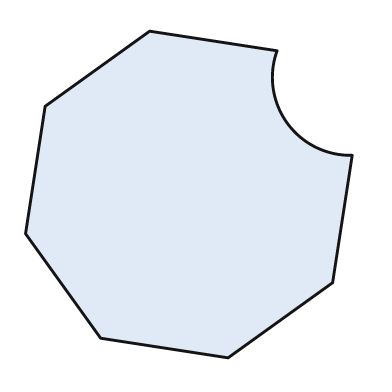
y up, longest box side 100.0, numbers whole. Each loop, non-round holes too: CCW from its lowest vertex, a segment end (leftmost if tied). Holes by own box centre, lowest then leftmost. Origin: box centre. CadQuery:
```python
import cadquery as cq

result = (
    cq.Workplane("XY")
    .moveTo(12.0, -50.0)
    .lineTo(44.0, -27.0)
    .lineTo(50.0, 12.0)
    .threePointArc((30.0, 22.0), (27.0, 44.0))
    .lineTo(-12.0, 50.0)
    .lineTo(-44.0, 27.0)
    .lineTo(-50.0, -12.0)
    .lineTo(-27.0, -44.0)
    .close()
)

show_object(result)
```